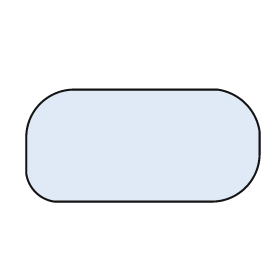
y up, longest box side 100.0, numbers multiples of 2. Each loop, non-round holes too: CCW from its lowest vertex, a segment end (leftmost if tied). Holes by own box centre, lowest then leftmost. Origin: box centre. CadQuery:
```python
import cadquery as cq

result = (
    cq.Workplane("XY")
    .moveTo(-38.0, -24.0)
    .lineTo(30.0, -24.0)
    .threePointArc((44.0, -18.0), (50.0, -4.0))
    .lineTo(50.0, 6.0)
    .threePointArc((44.0, 18.0), (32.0, 24.0))
    .lineTo(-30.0, 24.0)
    .threePointArc((-44.0, 18.0), (-50.0, 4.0))
    .lineTo(-50.0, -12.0)
    .threePointArc((-46.0, -20.0), (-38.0, -24.0))
    .close()
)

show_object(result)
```